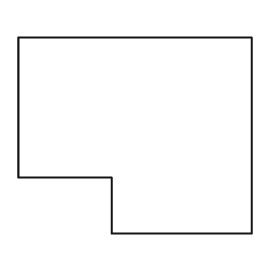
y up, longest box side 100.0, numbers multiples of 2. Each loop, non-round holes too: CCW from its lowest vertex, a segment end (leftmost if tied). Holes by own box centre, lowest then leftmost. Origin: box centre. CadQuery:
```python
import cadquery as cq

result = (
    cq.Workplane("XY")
    .moveTo(-10.0, -42.0)
    .lineTo(50.0, -42.0)
    .lineTo(50.0, 42.0)
    .lineTo(-50.0, 42.0)
    .lineTo(-50.0, -18.0)
    .lineTo(-10.0, -18.0)
    .close()
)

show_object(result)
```